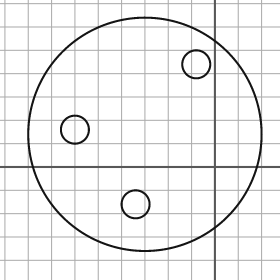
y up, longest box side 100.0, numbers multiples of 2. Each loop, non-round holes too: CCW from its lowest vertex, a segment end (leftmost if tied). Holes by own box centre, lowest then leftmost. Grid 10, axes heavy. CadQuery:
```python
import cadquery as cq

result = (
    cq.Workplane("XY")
    .moveTo(-30.0, 14.0)
    .circle(50.0)
    .moveTo(-34.0, -16.0)
    .circle(6.0)
    .moveTo(-60.0, 16.0)
    .circle(6.0)
    .moveTo(-8.0, 44.0)
    .circle(6.0)
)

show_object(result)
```